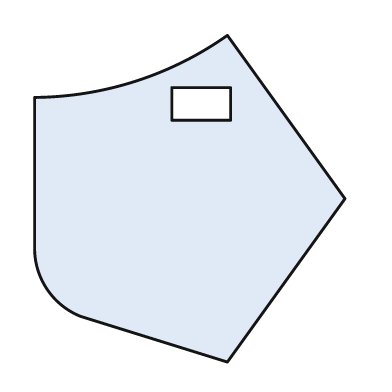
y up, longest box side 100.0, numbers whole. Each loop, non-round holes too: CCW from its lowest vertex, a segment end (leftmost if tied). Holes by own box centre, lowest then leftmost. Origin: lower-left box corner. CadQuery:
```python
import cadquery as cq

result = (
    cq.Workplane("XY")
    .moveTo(59.0, 0.0)
    .lineTo(95.0, 50.0)
    .lineTo(59.0, 100.0)
    .threePointArc((31.0, 86.0), (0.0, 81.0))
    .lineTo(0.0, 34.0)
    .threePointArc((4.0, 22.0), (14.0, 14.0))
    .close()
    .moveTo(42.0, 74.0)
    .lineTo(60.0, 74.0)
    .lineTo(60.0, 84.0)
    .lineTo(42.0, 84.0)
    .close()
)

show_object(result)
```